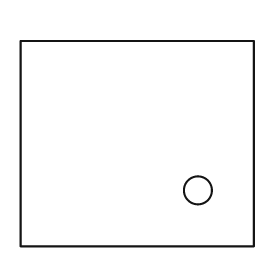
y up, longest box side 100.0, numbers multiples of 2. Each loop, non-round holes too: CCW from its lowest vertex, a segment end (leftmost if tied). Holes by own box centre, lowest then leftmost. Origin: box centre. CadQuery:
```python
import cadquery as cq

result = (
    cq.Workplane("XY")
    .moveTo(-50.0, -44.0)
    .lineTo(50.0, -44.0)
    .lineTo(50.0, 44.0)
    .lineTo(-50.0, 44.0)
    .close()
    .moveTo(26.0, -20.0)
    .circle(6.0)
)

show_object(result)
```